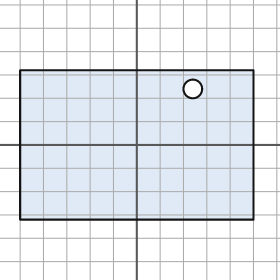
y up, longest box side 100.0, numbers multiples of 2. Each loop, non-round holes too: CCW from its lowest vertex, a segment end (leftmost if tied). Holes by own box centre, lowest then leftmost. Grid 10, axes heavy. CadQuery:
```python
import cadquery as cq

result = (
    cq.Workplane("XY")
    .moveTo(-50.0, -32.0)
    .lineTo(50.0, -32.0)
    .lineTo(50.0, 32.0)
    .lineTo(-50.0, 32.0)
    .close()
    .moveTo(24.0, 24.0)
    .circle(4.0)
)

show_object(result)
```